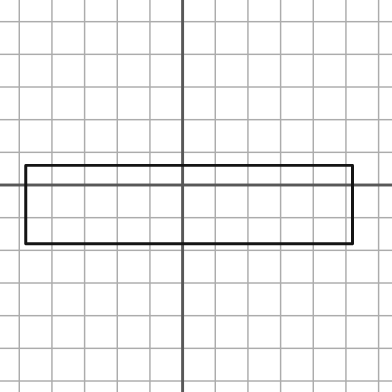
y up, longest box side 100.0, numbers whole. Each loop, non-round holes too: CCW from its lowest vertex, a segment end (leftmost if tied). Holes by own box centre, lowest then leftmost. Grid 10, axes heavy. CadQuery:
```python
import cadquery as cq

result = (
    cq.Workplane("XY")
    .moveTo(-48.0, -18.0)
    .lineTo(52.0, -18.0)
    .lineTo(52.0, 6.0)
    .lineTo(-48.0, 6.0)
    .close()
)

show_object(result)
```